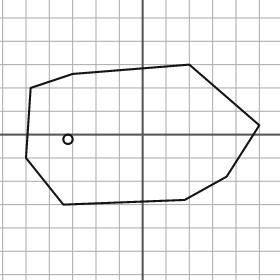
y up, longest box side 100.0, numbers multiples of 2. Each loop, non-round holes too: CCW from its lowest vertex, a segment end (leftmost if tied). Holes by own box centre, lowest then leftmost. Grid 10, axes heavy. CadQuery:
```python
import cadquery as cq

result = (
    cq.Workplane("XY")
    .moveTo(-34.0, -30.0)
    .lineTo(18.0, -28.0)
    .lineTo(36.0, -18.0)
    .lineTo(50.0, 4.0)
    .lineTo(20.0, 30.0)
    .lineTo(-30.0, 26.0)
    .lineTo(-48.0, 20.0)
    .lineTo(-50.0, -10.0)
    .close()
    .moveTo(-32.0, -2.0)
    .circle(2.0)
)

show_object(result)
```